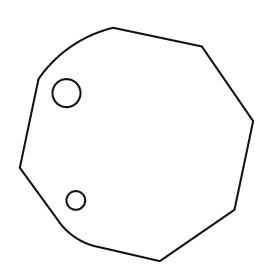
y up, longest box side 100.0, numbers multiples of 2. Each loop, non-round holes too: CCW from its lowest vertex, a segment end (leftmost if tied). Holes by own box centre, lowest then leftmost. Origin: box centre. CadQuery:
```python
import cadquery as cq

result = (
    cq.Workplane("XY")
    .moveTo(10.0, -50.0)
    .lineTo(42.0, -28.0)
    .lineTo(50.0, 10.0)
    .lineTo(28.0, 42.0)
    .lineTo(-10.0, 50.0)
    .threePointArc((-28.0, 42.0), (-42.0, 28.0))
    .lineTo(-50.0, -10.0)
    .lineTo(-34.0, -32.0)
    .threePointArc((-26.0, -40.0), (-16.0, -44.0))
    .close()
    .moveTo(-26.0, -24.0)
    .circle(4.0)
    .moveTo(-30.0, 22.0)
    .circle(6.0)
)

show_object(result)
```